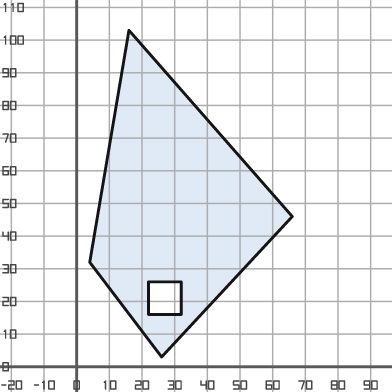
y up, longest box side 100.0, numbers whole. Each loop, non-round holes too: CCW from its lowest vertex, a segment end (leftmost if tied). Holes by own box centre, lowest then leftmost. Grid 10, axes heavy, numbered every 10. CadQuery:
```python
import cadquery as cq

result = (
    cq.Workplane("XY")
    .moveTo(26.0, 3.0)
    .lineTo(66.0, 46.0)
    .lineTo(16.0, 103.0)
    .lineTo(4.0, 32.0)
    .close()
    .moveTo(22.0, 16.0)
    .lineTo(32.0, 16.0)
    .lineTo(32.0, 26.0)
    .lineTo(22.0, 26.0)
    .close()
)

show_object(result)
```